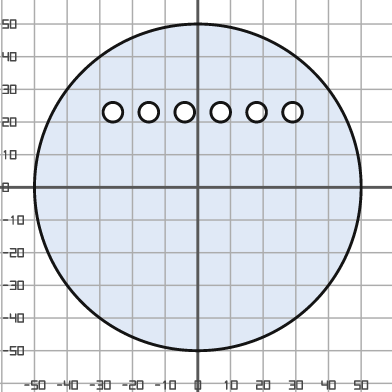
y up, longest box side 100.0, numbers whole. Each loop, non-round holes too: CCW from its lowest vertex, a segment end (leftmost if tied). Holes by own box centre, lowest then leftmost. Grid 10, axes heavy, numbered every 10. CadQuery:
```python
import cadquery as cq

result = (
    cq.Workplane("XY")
    .moveTo(0.0, 0.0)
    .circle(50.0)
    .moveTo(-26.0, 23.0)
    .circle(3.0)
    .moveTo(-15.0, 23.0)
    .circle(3.0)
    .moveTo(-4.0, 23.0)
    .circle(3.0)
    .moveTo(7.0, 23.0)
    .circle(3.0)
    .moveTo(18.0, 23.0)
    .circle(3.0)
    .moveTo(29.0, 23.0)
    .circle(3.0)
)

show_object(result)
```